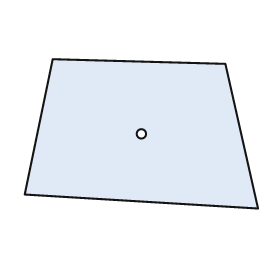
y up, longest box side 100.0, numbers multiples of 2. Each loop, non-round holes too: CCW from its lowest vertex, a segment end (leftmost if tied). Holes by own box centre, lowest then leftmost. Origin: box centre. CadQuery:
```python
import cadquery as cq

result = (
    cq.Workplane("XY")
    .moveTo(50.0, -32.0)
    .lineTo(36.0, 30.0)
    .lineTo(-38.0, 32.0)
    .lineTo(-50.0, -26.0)
    .close()
    .moveTo(0.0, 0.0)
    .circle(2.0)
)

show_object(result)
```